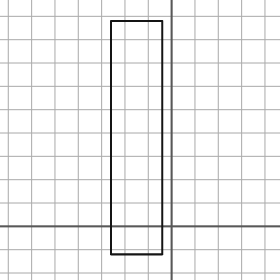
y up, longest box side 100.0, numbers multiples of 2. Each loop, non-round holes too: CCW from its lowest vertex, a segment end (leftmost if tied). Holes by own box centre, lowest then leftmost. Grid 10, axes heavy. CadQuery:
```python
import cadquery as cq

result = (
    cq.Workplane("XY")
    .moveTo(-26.0, -12.0)
    .lineTo(-4.0, -12.0)
    .lineTo(-4.0, 88.0)
    .lineTo(-26.0, 88.0)
    .close()
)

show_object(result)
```